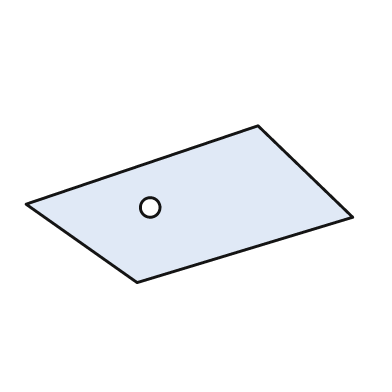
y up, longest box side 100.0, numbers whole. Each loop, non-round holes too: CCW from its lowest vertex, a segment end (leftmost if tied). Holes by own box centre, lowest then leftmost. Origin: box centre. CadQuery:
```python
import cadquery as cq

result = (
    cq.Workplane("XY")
    .moveTo(-16.0, -24.0)
    .lineTo(50.0, -4.0)
    .lineTo(21.0, 24.0)
    .lineTo(-50.0, 0.0)
    .close()
    .moveTo(-12.0, -1.0)
    .circle(3.0)
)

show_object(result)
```